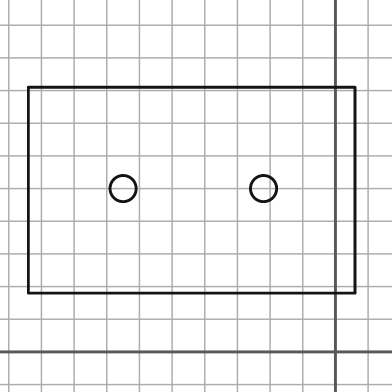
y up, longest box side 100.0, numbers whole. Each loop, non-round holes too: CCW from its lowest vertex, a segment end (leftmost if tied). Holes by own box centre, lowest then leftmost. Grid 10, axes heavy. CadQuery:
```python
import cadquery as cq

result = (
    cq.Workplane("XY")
    .moveTo(-94.0, 18.0)
    .lineTo(6.0, 18.0)
    .lineTo(6.0, 81.0)
    .lineTo(-94.0, 81.0)
    .close()
    .moveTo(-65.0, 50.0)
    .circle(4.0)
    .moveTo(-22.0, 50.0)
    .circle(4.0)
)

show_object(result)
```